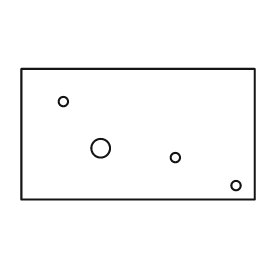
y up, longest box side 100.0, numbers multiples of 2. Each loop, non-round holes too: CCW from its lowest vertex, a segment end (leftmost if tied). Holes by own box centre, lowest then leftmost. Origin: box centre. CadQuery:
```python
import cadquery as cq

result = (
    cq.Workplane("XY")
    .moveTo(-50.0, -28.0)
    .lineTo(50.0, -28.0)
    .lineTo(50.0, 28.0)
    .lineTo(-50.0, 28.0)
    .close()
    .moveTo(42.0, -22.0)
    .circle(2.0)
    .moveTo(16.0, -10.0)
    .circle(2.0)
    .moveTo(-16.0, -6.0)
    .circle(4.0)
    .moveTo(-32.0, 14.0)
    .circle(2.0)
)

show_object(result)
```